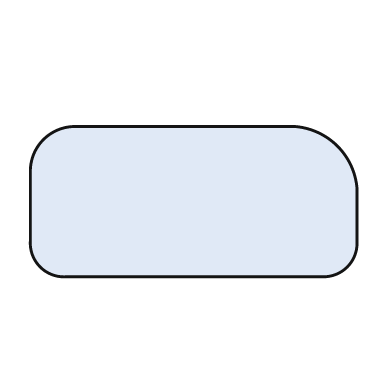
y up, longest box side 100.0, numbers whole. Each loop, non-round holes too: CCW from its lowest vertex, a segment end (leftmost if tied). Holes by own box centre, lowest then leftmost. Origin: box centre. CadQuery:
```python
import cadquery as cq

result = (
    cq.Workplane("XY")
    .moveTo(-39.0, -23.0)
    .lineTo(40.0, -23.0)
    .threePointArc((47.0, -20.0), (50.0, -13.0))
    .lineTo(50.0, 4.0)
    .threePointArc((44.0, 17.0), (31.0, 23.0))
    .lineTo(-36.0, 23.0)
    .threePointArc((-46.0, 19.0), (-50.0, 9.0))
    .lineTo(-50.0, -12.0)
    .threePointArc((-47.0, -20.0), (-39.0, -23.0))
    .close()
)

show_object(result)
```